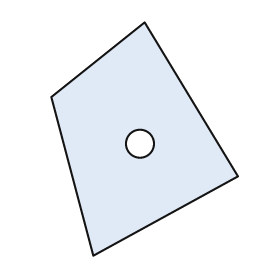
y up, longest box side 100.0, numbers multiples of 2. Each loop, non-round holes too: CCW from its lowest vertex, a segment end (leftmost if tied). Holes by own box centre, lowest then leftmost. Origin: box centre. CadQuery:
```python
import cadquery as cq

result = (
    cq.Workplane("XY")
    .moveTo(-22.0, -50.0)
    .lineTo(40.0, -16.0)
    .lineTo(0.0, 50.0)
    .lineTo(-40.0, 18.0)
    .close()
    .moveTo(-2.0, -2.0)
    .circle(6.0)
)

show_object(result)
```